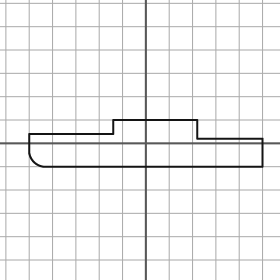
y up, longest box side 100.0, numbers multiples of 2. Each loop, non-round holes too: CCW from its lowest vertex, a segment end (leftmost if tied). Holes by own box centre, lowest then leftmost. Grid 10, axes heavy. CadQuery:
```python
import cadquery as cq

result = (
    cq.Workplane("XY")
    .moveTo(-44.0, -10.0)
    .lineTo(50.0, -10.0)
    .lineTo(50.0, 2.0)
    .lineTo(22.0, 2.0)
    .lineTo(22.0, 10.0)
    .lineTo(-14.0, 10.0)
    .lineTo(-14.0, 4.0)
    .lineTo(-50.0, 4.0)
    .lineTo(-50.0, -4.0)
    .threePointArc((-48.0, -8.0), (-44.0, -10.0))
    .close()
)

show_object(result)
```